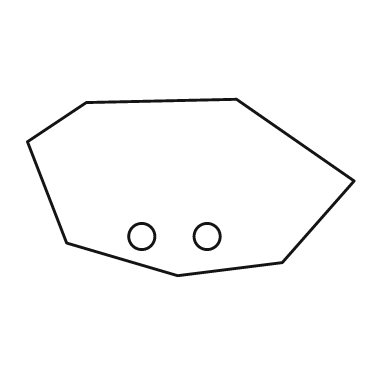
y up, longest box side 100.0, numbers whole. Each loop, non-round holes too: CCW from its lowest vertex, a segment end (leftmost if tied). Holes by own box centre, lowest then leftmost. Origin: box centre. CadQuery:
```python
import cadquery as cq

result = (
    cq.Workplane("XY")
    .moveTo(-4.0, -27.0)
    .lineTo(28.0, -23.0)
    .lineTo(50.0, 2.0)
    .lineTo(14.0, 27.0)
    .lineTo(-32.0, 26.0)
    .lineTo(-50.0, 14.0)
    .lineTo(-38.0, -17.0)
    .close()
    .moveTo(-15.0, -15.0)
    .circle(4.0)
    .moveTo(5.0, -15.0)
    .circle(4.0)
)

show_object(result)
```